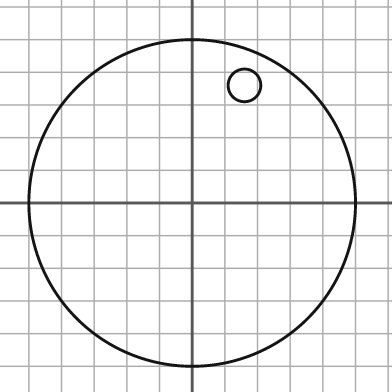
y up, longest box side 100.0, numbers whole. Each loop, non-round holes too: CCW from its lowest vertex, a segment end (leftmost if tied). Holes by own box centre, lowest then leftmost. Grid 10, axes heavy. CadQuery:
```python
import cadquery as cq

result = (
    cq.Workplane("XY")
    .moveTo(0.0, 0.0)
    .circle(50.0)
    .moveTo(16.0, 36.0)
    .circle(5.0)
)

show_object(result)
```